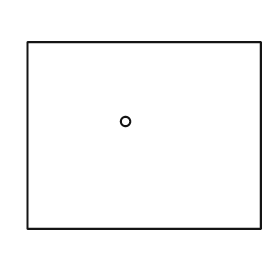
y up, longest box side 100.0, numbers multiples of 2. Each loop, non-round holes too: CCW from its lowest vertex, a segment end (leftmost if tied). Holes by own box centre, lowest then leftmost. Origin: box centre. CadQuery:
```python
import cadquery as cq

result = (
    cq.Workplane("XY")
    .moveTo(-50.0, -40.0)
    .lineTo(50.0, -40.0)
    .lineTo(50.0, 40.0)
    .lineTo(-50.0, 40.0)
    .close()
    .moveTo(-8.0, 6.0)
    .circle(2.0)
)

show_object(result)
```